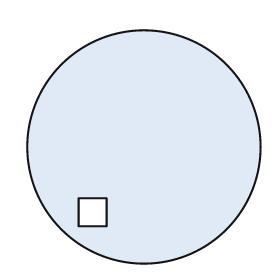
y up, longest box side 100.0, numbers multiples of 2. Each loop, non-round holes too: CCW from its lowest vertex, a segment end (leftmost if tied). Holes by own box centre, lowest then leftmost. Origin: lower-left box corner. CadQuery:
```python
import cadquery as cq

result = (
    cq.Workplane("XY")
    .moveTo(50.0, 50.0)
    .circle(50.0)
    .moveTo(22.0, 16.0)
    .lineTo(34.0, 16.0)
    .lineTo(34.0, 28.0)
    .lineTo(22.0, 28.0)
    .close()
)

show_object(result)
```